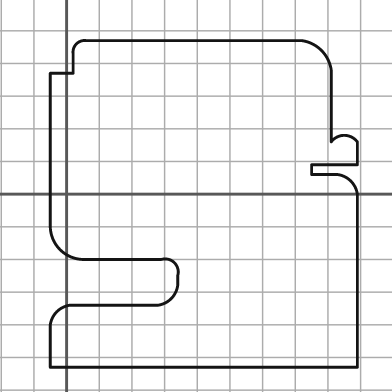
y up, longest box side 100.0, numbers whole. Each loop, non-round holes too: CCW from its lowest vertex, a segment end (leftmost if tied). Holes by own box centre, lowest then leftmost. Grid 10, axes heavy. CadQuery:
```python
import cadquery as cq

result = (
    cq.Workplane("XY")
    .moveTo(-5.0, -53.0)
    .lineTo(89.0, -53.0)
    .lineTo(89.0, 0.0)
    .threePointArc((87.0, 4.0), (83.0, 6.0))
    .lineTo(75.0, 6.0)
    .lineTo(75.0, 9.0)
    .lineTo(89.0, 9.0)
    .lineTo(89.0, 16.0)
    .threePointArc((85.0, 18.0), (81.0, 16.0))
    .lineTo(81.0, 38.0)
    .threePointArc((78.0, 44.0), (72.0, 47.0))
    .lineTo(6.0, 47.0)
    .threePointArc((3.0, 46.0), (2.0, 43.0))
    .lineTo(2.0, 37.0)
    .lineTo(-5.0, 37.0)
    .lineTo(-5.0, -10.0)
    .threePointArc((-2.0, -17.0), (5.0, -20.0))
    .lineTo(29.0, -20.0)
    .threePointArc((33.0, -21.0), (34.0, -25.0))
    .lineTo(34.0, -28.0)
    .threePointArc((32.0, -32.0), (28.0, -34.0))
    .lineTo(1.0, -34.0)
    .threePointArc((-3.0, -36.0), (-5.0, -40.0))
    .close()
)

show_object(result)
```